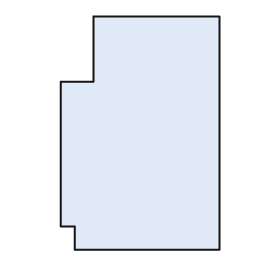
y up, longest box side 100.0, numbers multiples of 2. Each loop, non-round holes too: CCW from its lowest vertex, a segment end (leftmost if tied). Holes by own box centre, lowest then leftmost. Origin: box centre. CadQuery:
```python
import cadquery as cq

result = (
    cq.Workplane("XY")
    .moveTo(-28.0, -50.0)
    .lineTo(34.0, -50.0)
    .lineTo(34.0, 50.0)
    .lineTo(-20.0, 50.0)
    .lineTo(-20.0, 22.0)
    .lineTo(-34.0, 22.0)
    .lineTo(-34.0, -40.0)
    .lineTo(-28.0, -40.0)
    .close()
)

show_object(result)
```